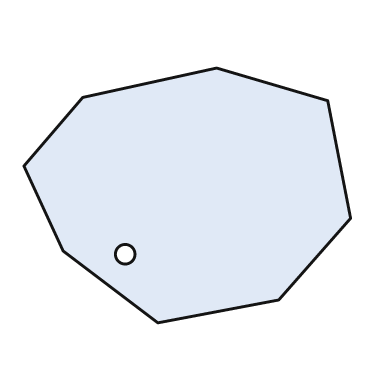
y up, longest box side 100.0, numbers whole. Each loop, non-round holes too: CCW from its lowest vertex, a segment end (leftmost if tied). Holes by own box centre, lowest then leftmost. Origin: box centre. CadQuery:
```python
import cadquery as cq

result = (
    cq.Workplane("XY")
    .moveTo(-9.0, -39.0)
    .lineTo(28.0, -32.0)
    .lineTo(50.0, -7.0)
    .lineTo(43.0, 29.0)
    .lineTo(9.0, 39.0)
    .lineTo(-32.0, 30.0)
    .lineTo(-50.0, 9.0)
    .lineTo(-38.0, -17.0)
    .close()
    .moveTo(-19.0, -18.0)
    .circle(3.0)
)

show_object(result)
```